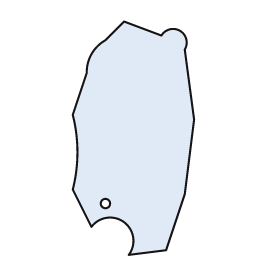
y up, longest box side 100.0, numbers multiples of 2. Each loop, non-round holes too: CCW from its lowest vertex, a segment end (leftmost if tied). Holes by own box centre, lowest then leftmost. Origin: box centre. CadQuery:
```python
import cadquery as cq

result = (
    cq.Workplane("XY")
    .moveTo(-2.0, -50.0)
    .lineTo(14.0, -48.0)
    .lineTo(22.0, -24.0)
    .lineTo(26.0, 8.0)
    .lineTo(22.0, 38.0)
    .threePointArc((20.0, 46.0), (12.0, 44.0))
    .lineTo(-4.0, 50.0)
    .lineTo(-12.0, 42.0)
    .threePointArc((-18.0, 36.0), (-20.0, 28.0))
    .lineTo(-26.0, 10.0)
    .threePointArc((-24.0, -6.0), (-26.0, -22.0))
    .lineTo(-18.0, -38.0)
    .threePointArc((-4.0, -36.0), (-2.0, -50.0))
    .close()
    .moveTo(-12.0, -28.0)
    .circle(2.0)
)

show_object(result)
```